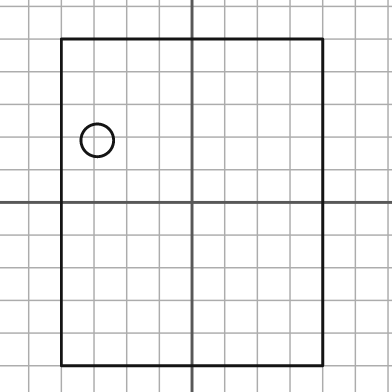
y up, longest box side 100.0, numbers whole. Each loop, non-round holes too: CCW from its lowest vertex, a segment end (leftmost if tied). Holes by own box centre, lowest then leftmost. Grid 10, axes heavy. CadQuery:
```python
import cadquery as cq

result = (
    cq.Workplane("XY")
    .moveTo(-40.0, -50.0)
    .lineTo(40.0, -50.0)
    .lineTo(40.0, 50.0)
    .lineTo(-40.0, 50.0)
    .close()
    .moveTo(-29.0, 19.0)
    .circle(5.0)
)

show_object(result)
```